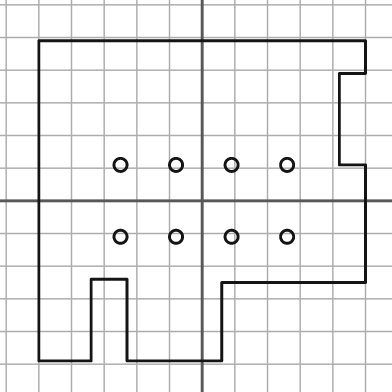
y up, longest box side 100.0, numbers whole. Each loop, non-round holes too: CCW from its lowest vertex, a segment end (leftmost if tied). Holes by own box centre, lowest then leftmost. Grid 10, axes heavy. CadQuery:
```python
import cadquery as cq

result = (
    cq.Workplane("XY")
    .moveTo(-50.0, -49.0)
    .lineTo(-34.0, -49.0)
    .lineTo(-34.0, -24.0)
    .lineTo(-23.0, -24.0)
    .lineTo(-23.0, -49.0)
    .lineTo(6.0, -49.0)
    .lineTo(6.0, -25.0)
    .lineTo(50.0, -25.0)
    .lineTo(50.0, 11.0)
    .lineTo(42.0, 11.0)
    .lineTo(42.0, 39.0)
    .lineTo(50.0, 39.0)
    .lineTo(50.0, 49.0)
    .lineTo(-50.0, 49.0)
    .close()
    .moveTo(-25.0, -11.0)
    .circle(2.0)
    .moveTo(-8.0, -11.0)
    .circle(2.0)
    .moveTo(9.0, -11.0)
    .circle(2.0)
    .moveTo(26.0, -11.0)
    .circle(2.0)
    .moveTo(-25.0, 11.0)
    .circle(2.0)
    .moveTo(-8.0, 11.0)
    .circle(2.0)
    .moveTo(9.0, 11.0)
    .circle(2.0)
    .moveTo(26.0, 11.0)
    .circle(2.0)
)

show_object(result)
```